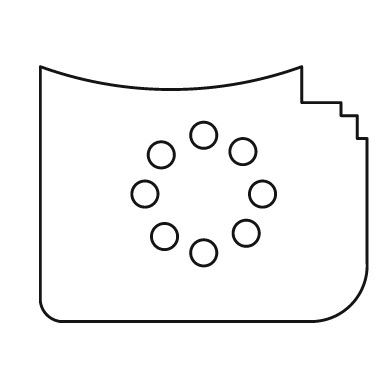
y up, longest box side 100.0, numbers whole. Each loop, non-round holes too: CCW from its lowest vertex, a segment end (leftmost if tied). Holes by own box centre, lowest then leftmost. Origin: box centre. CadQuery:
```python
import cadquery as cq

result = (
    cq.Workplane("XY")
    .moveTo(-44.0, -39.0)
    .lineTo(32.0, -39.0)
    .threePointArc((45.0, -34.0), (50.0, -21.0))
    .lineTo(50.0, 17.0)
    .lineTo(47.0, 17.0)
    .lineTo(47.0, 24.0)
    .lineTo(42.0, 24.0)
    .lineTo(42.0, 28.0)
    .lineTo(30.0, 28.0)
    .lineTo(30.0, 39.0)
    .threePointArc((-10.0, 32.0), (-50.0, 39.0))
    .lineTo(-50.0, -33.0)
    .threePointArc((-48.0, -37.0), (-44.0, -39.0))
    .close()
    .moveTo(0.0, -18.0)
    .circle(4.0)
    .moveTo(-12.0, -13.0)
    .circle(4.0)
    .moveTo(13.0, -12.0)
    .circle(4.0)
    .moveTo(-18.0, 0.0)
    .circle(4.0)
    .moveTo(18.0, 0.0)
    .circle(4.0)
    .moveTo(-13.0, 12.0)
    .circle(4.0)
    .moveTo(12.0, 13.0)
    .circle(4.0)
    .moveTo(0.0, 18.0)
    .circle(4.0)
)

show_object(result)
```